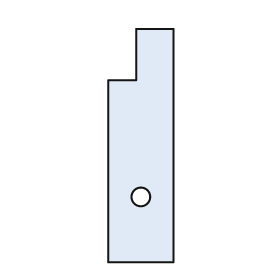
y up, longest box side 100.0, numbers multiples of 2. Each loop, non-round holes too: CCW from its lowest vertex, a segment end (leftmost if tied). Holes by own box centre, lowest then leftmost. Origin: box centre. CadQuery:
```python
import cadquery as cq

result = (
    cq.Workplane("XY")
    .moveTo(-14.0, -50.0)
    .lineTo(14.0, -50.0)
    .lineTo(14.0, 50.0)
    .lineTo(-2.0, 50.0)
    .lineTo(-2.0, 28.0)
    .lineTo(-14.0, 28.0)
    .close()
    .moveTo(0.0, -22.0)
    .circle(4.0)
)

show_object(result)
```